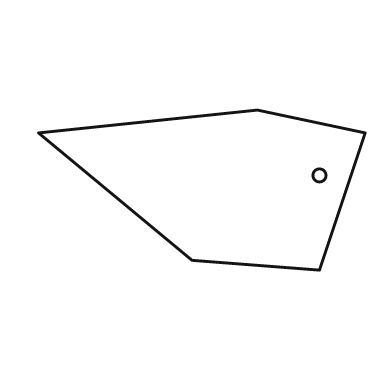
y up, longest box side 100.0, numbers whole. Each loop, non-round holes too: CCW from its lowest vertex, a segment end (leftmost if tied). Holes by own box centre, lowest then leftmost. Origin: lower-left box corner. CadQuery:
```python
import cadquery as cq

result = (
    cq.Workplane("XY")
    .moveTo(86.0, 0.0)
    .lineTo(100.0, 42.0)
    .lineTo(67.0, 49.0)
    .lineTo(0.0, 42.0)
    .lineTo(47.0, 3.0)
    .close()
    .moveTo(86.0, 29.0)
    .circle(2.0)
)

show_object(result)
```